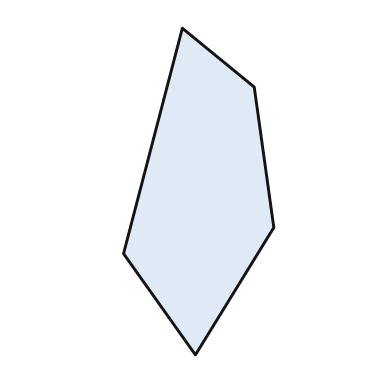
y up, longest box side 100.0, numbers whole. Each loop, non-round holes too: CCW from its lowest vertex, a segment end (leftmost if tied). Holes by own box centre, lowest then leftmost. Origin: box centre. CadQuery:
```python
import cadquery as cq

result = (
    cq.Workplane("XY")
    .moveTo(-1.0, -50.0)
    .lineTo(23.0, -11.0)
    .lineTo(17.0, 32.0)
    .lineTo(-5.0, 50.0)
    .lineTo(-23.0, -19.0)
    .close()
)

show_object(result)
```